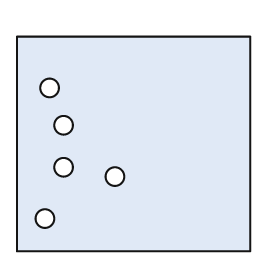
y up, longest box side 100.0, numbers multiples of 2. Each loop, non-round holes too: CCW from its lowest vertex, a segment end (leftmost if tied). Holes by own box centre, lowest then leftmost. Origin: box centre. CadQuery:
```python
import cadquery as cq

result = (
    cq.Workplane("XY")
    .moveTo(-50.0, -46.0)
    .lineTo(50.0, -46.0)
    .lineTo(50.0, 46.0)
    .lineTo(-50.0, 46.0)
    .close()
    .moveTo(-38.0, -32.0)
    .circle(4.0)
    .moveTo(-8.0, -14.0)
    .circle(4.0)
    .moveTo(-30.0, -10.0)
    .circle(4.0)
    .moveTo(-30.0, 8.0)
    .circle(4.0)
    .moveTo(-36.0, 24.0)
    .circle(4.0)
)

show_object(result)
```